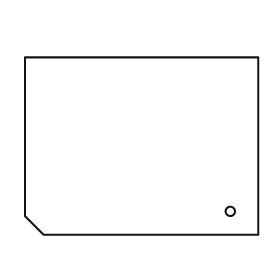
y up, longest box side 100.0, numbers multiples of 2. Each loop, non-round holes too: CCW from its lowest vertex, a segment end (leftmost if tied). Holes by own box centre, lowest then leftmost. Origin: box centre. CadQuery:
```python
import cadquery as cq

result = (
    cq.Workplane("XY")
    .moveTo(-42.0, -38.0)
    .lineTo(50.0, -38.0)
    .lineTo(50.0, 38.0)
    .lineTo(-50.0, 38.0)
    .lineTo(-50.0, -30.0)
    .close()
    .moveTo(38.0, -28.0)
    .circle(2.0)
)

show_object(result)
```